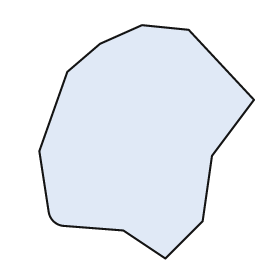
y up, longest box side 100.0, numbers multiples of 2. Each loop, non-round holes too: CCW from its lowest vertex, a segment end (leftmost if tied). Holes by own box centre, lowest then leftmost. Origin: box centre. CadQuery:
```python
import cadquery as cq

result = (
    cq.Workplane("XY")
    .moveTo(8.0, -50.0)
    .lineTo(24.0, -34.0)
    .lineTo(28.0, -6.0)
    .lineTo(46.0, 18.0)
    .lineTo(18.0, 48.0)
    .lineTo(-2.0, 50.0)
    .lineTo(-20.0, 42.0)
    .lineTo(-34.0, 30.0)
    .lineTo(-46.0, -4.0)
    .lineTo(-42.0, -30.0)
    .threePointArc((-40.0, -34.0), (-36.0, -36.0))
    .lineTo(-10.0, -38.0)
    .close()
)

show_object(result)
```